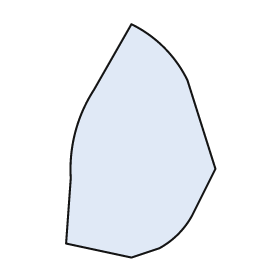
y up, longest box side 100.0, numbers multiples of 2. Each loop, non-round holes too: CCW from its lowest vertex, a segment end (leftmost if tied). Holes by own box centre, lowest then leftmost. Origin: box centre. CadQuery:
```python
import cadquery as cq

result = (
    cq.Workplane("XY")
    .moveTo(-4.0, -50.0)
    .lineTo(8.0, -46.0)
    .threePointArc((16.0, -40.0), (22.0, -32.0))
    .lineTo(32.0, -12.0)
    .lineTo(20.0, 26.0)
    .threePointArc((10.0, 40.0), (-4.0, 50.0))
    .lineTo(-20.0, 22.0)
    .threePointArc((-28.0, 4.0), (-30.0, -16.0))
    .lineTo(-32.0, -44.0)
    .close()
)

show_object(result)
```